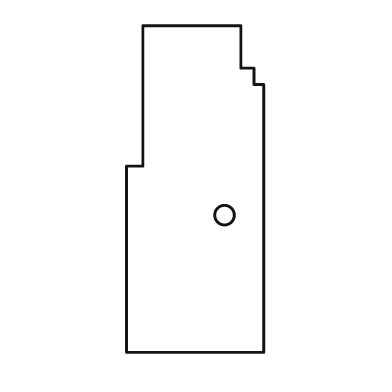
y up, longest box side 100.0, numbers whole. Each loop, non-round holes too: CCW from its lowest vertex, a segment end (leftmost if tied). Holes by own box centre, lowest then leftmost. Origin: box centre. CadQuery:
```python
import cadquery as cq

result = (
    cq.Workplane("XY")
    .moveTo(-21.0, -50.0)
    .lineTo(21.0, -50.0)
    .lineTo(21.0, 32.0)
    .lineTo(18.0, 32.0)
    .lineTo(18.0, 37.0)
    .lineTo(14.0, 37.0)
    .lineTo(14.0, 50.0)
    .lineTo(-16.0, 50.0)
    .lineTo(-16.0, 7.0)
    .lineTo(-21.0, 7.0)
    .close()
    .moveTo(9.0, -8.0)
    .circle(3.0)
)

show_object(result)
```